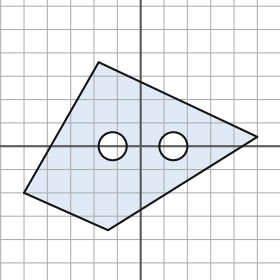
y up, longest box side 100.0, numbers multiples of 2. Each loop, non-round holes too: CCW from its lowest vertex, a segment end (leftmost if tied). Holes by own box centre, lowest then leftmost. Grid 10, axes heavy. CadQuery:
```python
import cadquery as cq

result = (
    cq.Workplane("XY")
    .moveTo(-14.0, -36.0)
    .lineTo(50.0, 4.0)
    .lineTo(-18.0, 36.0)
    .lineTo(-50.0, -20.0)
    .close()
    .moveTo(-12.0, 0.0)
    .circle(6.0)
    .moveTo(14.0, 0.0)
    .circle(6.0)
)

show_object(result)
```